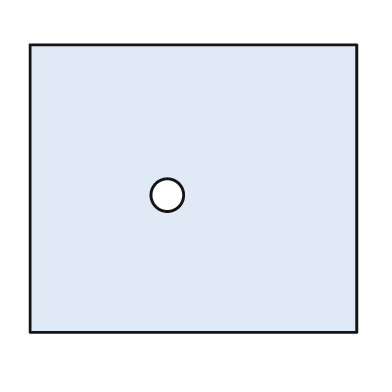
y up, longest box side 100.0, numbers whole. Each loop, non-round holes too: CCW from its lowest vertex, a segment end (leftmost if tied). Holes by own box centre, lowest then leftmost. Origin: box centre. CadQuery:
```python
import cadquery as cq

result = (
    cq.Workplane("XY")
    .moveTo(-50.0, -44.0)
    .lineTo(50.0, -44.0)
    .lineTo(50.0, 44.0)
    .lineTo(-50.0, 44.0)
    .close()
    .moveTo(-8.0, -2.0)
    .circle(5.0)
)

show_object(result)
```